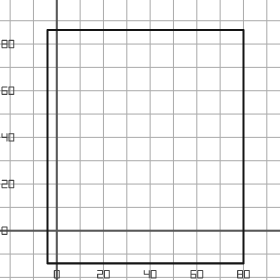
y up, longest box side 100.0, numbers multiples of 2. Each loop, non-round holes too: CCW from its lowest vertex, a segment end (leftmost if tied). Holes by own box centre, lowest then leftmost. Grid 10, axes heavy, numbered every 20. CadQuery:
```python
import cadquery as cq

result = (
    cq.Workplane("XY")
    .moveTo(-4.0, -14.0)
    .lineTo(80.0, -14.0)
    .lineTo(80.0, 86.0)
    .lineTo(-4.0, 86.0)
    .close()
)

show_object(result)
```